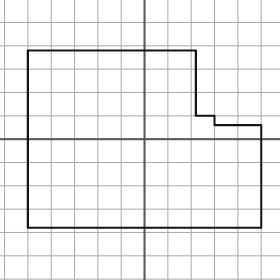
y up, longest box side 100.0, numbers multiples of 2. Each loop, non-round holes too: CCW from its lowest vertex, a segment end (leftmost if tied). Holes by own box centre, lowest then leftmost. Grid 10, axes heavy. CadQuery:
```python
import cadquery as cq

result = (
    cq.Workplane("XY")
    .moveTo(-50.0, -38.0)
    .lineTo(50.0, -38.0)
    .lineTo(50.0, 6.0)
    .lineTo(30.0, 6.0)
    .lineTo(30.0, 10.0)
    .lineTo(22.0, 10.0)
    .lineTo(22.0, 38.0)
    .lineTo(-50.0, 38.0)
    .close()
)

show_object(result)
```